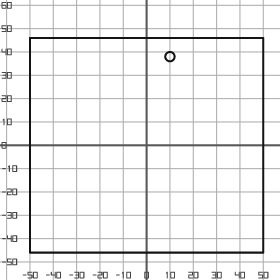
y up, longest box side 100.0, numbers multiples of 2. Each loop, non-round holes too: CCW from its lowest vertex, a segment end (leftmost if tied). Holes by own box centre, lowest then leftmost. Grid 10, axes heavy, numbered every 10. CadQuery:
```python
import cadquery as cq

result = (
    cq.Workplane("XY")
    .moveTo(-50.0, -46.0)
    .lineTo(50.0, -46.0)
    .lineTo(50.0, 46.0)
    .lineTo(-50.0, 46.0)
    .close()
    .moveTo(10.0, 38.0)
    .circle(2.0)
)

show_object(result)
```